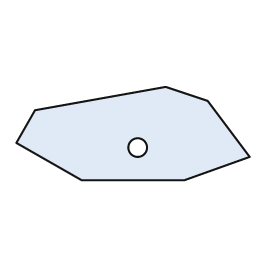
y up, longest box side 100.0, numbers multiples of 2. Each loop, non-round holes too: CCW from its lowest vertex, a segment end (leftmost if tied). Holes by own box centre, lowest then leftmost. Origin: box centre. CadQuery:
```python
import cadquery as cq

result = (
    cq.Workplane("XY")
    .moveTo(-22.0, -20.0)
    .lineTo(22.0, -20.0)
    .lineTo(50.0, -10.0)
    .lineTo(32.0, 14.0)
    .lineTo(14.0, 20.0)
    .lineTo(-42.0, 10.0)
    .lineTo(-50.0, -4.0)
    .close()
    .moveTo(2.0, -6.0)
    .circle(4.0)
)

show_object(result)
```